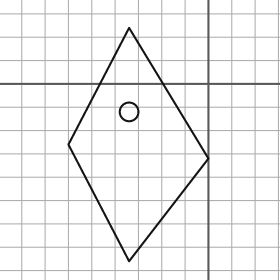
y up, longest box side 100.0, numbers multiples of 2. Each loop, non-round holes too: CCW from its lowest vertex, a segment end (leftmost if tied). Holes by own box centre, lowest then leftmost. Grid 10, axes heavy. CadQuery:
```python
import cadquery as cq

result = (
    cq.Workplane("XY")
    .moveTo(-34.0, -76.0)
    .lineTo(0.0, -32.0)
    .lineTo(-34.0, 24.0)
    .lineTo(-60.0, -26.0)
    .close()
    .moveTo(-34.0, -12.0)
    .circle(4.0)
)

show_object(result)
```